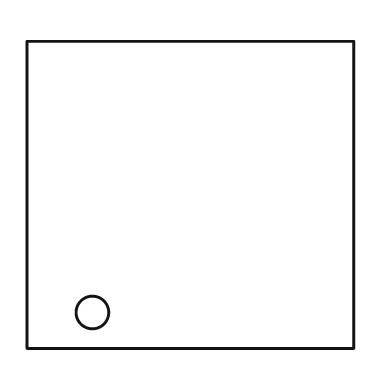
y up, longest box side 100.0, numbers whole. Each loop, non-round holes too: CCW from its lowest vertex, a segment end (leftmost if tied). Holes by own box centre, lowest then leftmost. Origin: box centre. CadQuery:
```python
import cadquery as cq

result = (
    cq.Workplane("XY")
    .moveTo(-50.0, -47.0)
    .lineTo(50.0, -47.0)
    .lineTo(50.0, 47.0)
    .lineTo(-50.0, 47.0)
    .close()
    .moveTo(-30.0, -36.0)
    .circle(5.0)
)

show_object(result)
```